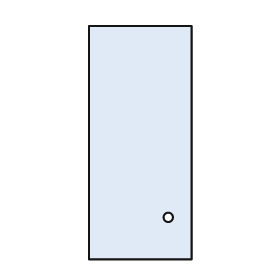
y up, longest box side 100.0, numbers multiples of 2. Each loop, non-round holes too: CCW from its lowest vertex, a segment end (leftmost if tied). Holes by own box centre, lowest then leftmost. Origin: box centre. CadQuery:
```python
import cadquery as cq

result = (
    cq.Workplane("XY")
    .moveTo(-22.0, -50.0)
    .lineTo(22.0, -50.0)
    .lineTo(22.0, 50.0)
    .lineTo(-22.0, 50.0)
    .close()
    .moveTo(12.0, -32.0)
    .circle(2.0)
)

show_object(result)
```